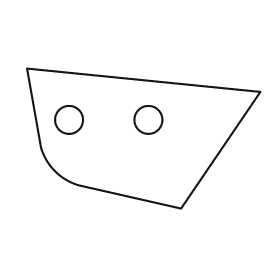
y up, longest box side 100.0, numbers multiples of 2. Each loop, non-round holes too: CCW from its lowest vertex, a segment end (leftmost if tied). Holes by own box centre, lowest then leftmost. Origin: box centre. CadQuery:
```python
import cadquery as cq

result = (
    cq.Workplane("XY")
    .moveTo(16.0, -30.0)
    .lineTo(50.0, 20.0)
    .lineTo(-50.0, 30.0)
    .lineTo(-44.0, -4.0)
    .threePointArc((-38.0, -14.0), (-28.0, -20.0))
    .close()
    .moveTo(-32.0, 8.0)
    .circle(6.0)
    .moveTo(2.0, 8.0)
    .circle(6.0)
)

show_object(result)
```